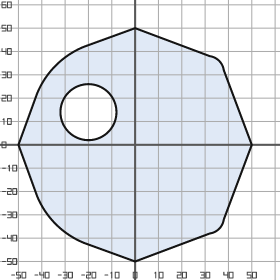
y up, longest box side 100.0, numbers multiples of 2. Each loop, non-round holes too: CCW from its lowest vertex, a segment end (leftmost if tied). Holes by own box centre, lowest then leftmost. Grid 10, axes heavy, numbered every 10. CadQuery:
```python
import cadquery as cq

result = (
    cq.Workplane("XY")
    .moveTo(0.0, -50.0)
    .lineTo(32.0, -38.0)
    .threePointArc((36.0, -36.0), (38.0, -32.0))
    .lineTo(50.0, 0.0)
    .lineTo(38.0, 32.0)
    .threePointArc((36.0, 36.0), (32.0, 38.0))
    .lineTo(0.0, 50.0)
    .lineTo(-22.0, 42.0)
    .threePointArc((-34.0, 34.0), (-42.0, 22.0))
    .lineTo(-50.0, 0.0)
    .lineTo(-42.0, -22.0)
    .threePointArc((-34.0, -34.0), (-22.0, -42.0))
    .close()
    .moveTo(-20.0, 14.0)
    .circle(12.0)
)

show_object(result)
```